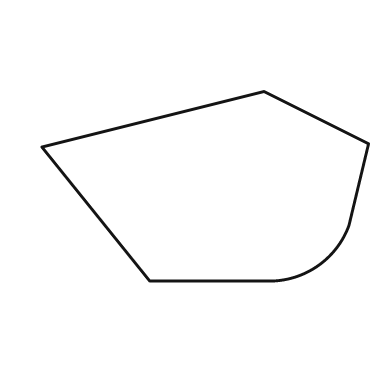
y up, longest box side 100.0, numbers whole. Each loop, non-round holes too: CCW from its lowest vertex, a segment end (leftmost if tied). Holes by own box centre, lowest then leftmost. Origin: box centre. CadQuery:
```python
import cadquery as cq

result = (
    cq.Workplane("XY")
    .moveTo(-17.0, -29.0)
    .lineTo(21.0, -29.0)
    .threePointArc((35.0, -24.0), (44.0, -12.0))
    .lineTo(50.0, 13.0)
    .lineTo(18.0, 29.0)
    .lineTo(-50.0, 12.0)
    .close()
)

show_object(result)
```